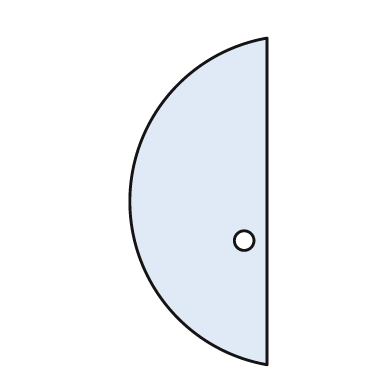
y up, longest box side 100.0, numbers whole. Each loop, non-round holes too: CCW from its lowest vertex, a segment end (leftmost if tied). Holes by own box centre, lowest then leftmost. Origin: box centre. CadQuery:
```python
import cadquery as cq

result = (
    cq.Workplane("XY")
    .moveTo(21.0, -50.0)
    .lineTo(21.0, 50.0)
    .threePointArc((-21.0, 0.0), (21.0, -50.0))
    .close()
    .moveTo(14.0, -12.0)
    .circle(3.0)
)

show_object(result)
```